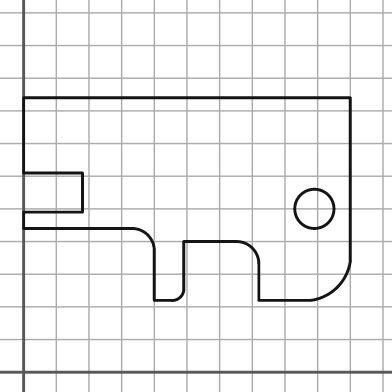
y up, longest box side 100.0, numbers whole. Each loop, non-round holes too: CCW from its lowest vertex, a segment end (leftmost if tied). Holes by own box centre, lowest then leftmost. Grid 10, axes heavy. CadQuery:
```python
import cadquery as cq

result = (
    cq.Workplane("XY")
    .moveTo(40.0, 22.0)
    .lineTo(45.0, 22.0)
    .threePointArc((48.0, 23.0), (49.0, 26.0))
    .lineTo(49.0, 40.0)
    .lineTo(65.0, 40.0)
    .threePointArc((70.0, 38.0), (72.0, 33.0))
    .lineTo(72.0, 22.0)
    .lineTo(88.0, 22.0)
    .threePointArc((96.0, 26.0), (100.0, 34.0))
    .lineTo(100.0, 84.0)
    .lineTo(0.0, 84.0)
    .lineTo(0.0, 61.0)
    .lineTo(18.0, 61.0)
    .lineTo(18.0, 49.0)
    .lineTo(0.0, 49.0)
    .lineTo(0.0, 44.0)
    .lineTo(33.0, 44.0)
    .threePointArc((38.0, 42.0), (40.0, 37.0))
    .close()
    .moveTo(89.0, 50.0)
    .circle(6.0)
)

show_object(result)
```